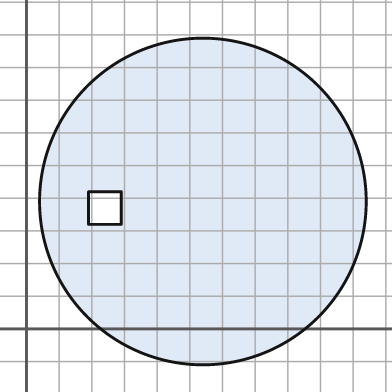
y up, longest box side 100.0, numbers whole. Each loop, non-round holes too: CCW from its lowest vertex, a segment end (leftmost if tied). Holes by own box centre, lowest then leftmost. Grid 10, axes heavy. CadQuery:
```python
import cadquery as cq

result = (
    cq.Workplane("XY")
    .moveTo(54.0, 39.0)
    .circle(50.0)
    .moveTo(19.0, 32.0)
    .lineTo(29.0, 32.0)
    .lineTo(29.0, 42.0)
    .lineTo(19.0, 42.0)
    .close()
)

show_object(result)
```